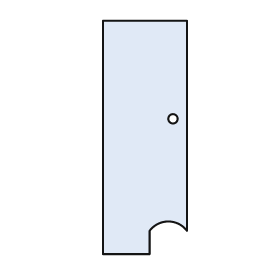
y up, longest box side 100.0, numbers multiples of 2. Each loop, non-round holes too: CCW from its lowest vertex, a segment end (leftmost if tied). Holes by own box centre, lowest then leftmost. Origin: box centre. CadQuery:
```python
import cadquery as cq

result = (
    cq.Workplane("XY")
    .moveTo(-18.0, -50.0)
    .lineTo(2.0, -50.0)
    .lineTo(2.0, -40.0)
    .threePointArc((10.0, -36.0), (18.0, -40.0))
    .lineTo(18.0, 50.0)
    .lineTo(-18.0, 50.0)
    .close()
    .moveTo(12.0, 8.0)
    .circle(2.0)
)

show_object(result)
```